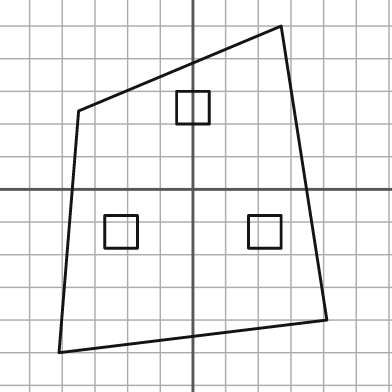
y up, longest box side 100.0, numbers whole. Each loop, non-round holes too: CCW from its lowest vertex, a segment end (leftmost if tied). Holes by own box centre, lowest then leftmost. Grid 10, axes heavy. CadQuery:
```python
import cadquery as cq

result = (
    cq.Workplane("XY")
    .moveTo(-41.0, -50.0)
    .lineTo(41.0, -40.0)
    .lineTo(27.0, 50.0)
    .lineTo(-35.0, 24.0)
    .close()
    .moveTo(-27.0, -18.0)
    .lineTo(-17.0, -18.0)
    .lineTo(-17.0, -8.0)
    .lineTo(-27.0, -8.0)
    .close()
    .moveTo(17.0, -18.0)
    .lineTo(27.0, -18.0)
    .lineTo(27.0, -8.0)
    .lineTo(17.0, -8.0)
    .close()
    .moveTo(-5.0, 20.0)
    .lineTo(5.0, 20.0)
    .lineTo(5.0, 30.0)
    .lineTo(-5.0, 30.0)
    .close()
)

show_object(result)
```